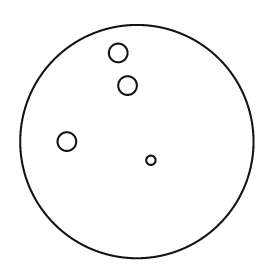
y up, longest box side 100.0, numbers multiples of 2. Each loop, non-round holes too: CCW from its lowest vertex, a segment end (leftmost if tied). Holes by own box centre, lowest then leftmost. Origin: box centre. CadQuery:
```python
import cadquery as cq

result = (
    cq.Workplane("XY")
    .moveTo(0.0, 0.0)
    .circle(50.0)
    .moveTo(6.0, -8.0)
    .circle(2.0)
    .moveTo(-30.0, 0.0)
    .circle(4.0)
    .moveTo(-4.0, 24.0)
    .circle(4.0)
    .moveTo(-8.0, 38.0)
    .circle(4.0)
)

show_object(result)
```